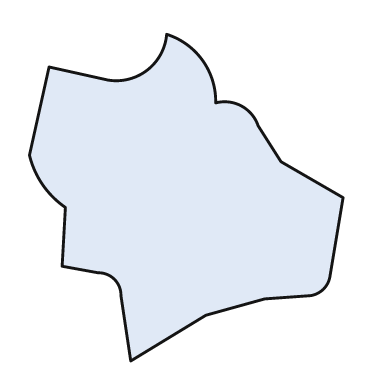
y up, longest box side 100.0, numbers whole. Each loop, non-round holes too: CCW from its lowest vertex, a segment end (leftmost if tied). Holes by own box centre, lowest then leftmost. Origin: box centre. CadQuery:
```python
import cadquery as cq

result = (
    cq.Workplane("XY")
    .moveTo(-17.0, -50.0)
    .lineTo(6.0, -36.0)
    .lineTo(24.0, -31.0)
    .lineTo(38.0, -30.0)
    .threePointArc((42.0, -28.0), (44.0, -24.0))
    .lineTo(48.0, 0.0)
    .lineTo(29.0, 11.0)
    .lineTo(22.0, 22.0)
    .threePointArc((17.0, 28.0), (9.0, 29.0))
    .threePointArc((5.0, 42.0), (-6.0, 50.0))
    .threePointArc((-12.0, 39.0), (-24.0, 36.0))
    .lineTo(-42.0, 40.0)
    .lineTo(-48.0, 13.0)
    .threePointArc((-44.0, 4.0), (-37.0, -3.0))
    .lineTo(-38.0, -21.0)
    .lineTo(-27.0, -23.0)
    .threePointArc((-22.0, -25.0), (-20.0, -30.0))
    .close()
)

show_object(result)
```